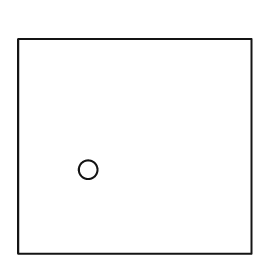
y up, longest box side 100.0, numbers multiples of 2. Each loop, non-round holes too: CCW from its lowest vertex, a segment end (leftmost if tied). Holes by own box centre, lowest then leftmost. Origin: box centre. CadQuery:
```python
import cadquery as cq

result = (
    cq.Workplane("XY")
    .moveTo(-50.0, -46.0)
    .lineTo(50.0, -46.0)
    .lineTo(50.0, 46.0)
    .lineTo(-50.0, 46.0)
    .close()
    .moveTo(-20.0, -10.0)
    .circle(4.0)
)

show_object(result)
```